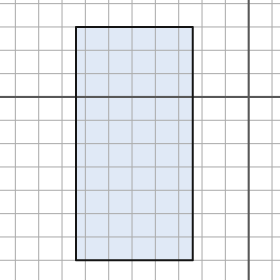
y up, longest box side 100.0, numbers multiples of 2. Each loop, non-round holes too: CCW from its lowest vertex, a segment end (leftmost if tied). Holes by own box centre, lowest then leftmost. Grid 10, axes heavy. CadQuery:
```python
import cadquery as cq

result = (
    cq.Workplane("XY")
    .moveTo(-74.0, -70.0)
    .lineTo(-24.0, -70.0)
    .lineTo(-24.0, 30.0)
    .lineTo(-74.0, 30.0)
    .close()
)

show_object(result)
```